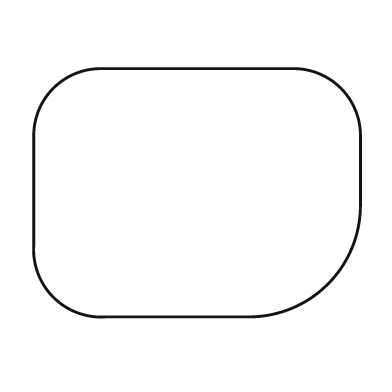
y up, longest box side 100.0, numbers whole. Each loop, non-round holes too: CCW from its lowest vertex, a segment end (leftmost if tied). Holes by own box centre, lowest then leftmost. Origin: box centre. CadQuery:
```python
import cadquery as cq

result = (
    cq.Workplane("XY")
    .moveTo(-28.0, -38.0)
    .lineTo(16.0, -38.0)
    .threePointArc((40.0, -28.0), (50.0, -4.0))
    .lineTo(50.0, 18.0)
    .threePointArc((44.0, 32.0), (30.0, 38.0))
    .lineTo(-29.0, 38.0)
    .threePointArc((-44.0, 32.0), (-50.0, 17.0))
    .lineTo(-50.0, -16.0)
    .threePointArc((-44.0, -32.0), (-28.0, -38.0))
    .close()
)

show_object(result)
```